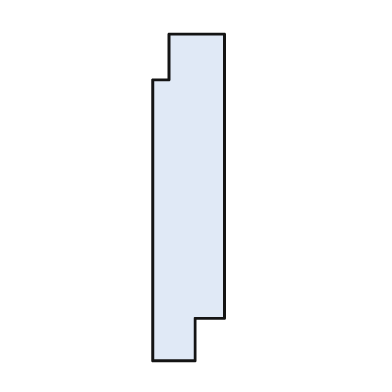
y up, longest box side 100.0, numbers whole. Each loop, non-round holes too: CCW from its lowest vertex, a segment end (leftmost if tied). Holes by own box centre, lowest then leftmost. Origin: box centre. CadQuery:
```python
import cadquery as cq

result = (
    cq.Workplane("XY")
    .moveTo(-11.0, -50.0)
    .lineTo(2.0, -50.0)
    .lineTo(2.0, -37.0)
    .lineTo(11.0, -37.0)
    .lineTo(11.0, 50.0)
    .lineTo(-6.0, 50.0)
    .lineTo(-6.0, 36.0)
    .lineTo(-11.0, 36.0)
    .close()
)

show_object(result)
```